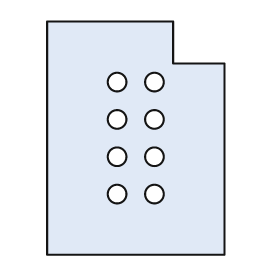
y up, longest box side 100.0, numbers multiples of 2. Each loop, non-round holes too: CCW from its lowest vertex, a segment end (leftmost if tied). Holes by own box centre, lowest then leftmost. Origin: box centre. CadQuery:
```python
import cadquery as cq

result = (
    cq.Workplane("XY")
    .moveTo(-38.0, -50.0)
    .lineTo(38.0, -50.0)
    .lineTo(38.0, 32.0)
    .lineTo(16.0, 32.0)
    .lineTo(16.0, 50.0)
    .lineTo(-38.0, 50.0)
    .close()
    .moveTo(-8.0, -24.0)
    .circle(4.0)
    .moveTo(8.0, -24.0)
    .circle(4.0)
    .moveTo(-8.0, -8.0)
    .circle(4.0)
    .moveTo(8.0, -8.0)
    .circle(4.0)
    .moveTo(-8.0, 8.0)
    .circle(4.0)
    .moveTo(8.0, 8.0)
    .circle(4.0)
    .moveTo(-8.0, 24.0)
    .circle(4.0)
    .moveTo(8.0, 24.0)
    .circle(4.0)
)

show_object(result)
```